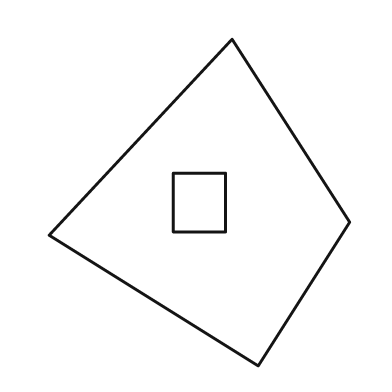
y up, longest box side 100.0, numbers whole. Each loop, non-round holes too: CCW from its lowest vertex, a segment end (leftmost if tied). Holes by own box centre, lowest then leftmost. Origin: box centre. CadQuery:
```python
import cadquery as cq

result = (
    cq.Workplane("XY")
    .moveTo(18.0, -50.0)
    .lineTo(46.0, -6.0)
    .lineTo(10.0, 50.0)
    .lineTo(-46.0, -10.0)
    .close()
    .moveTo(-8.0, -9.0)
    .lineTo(8.0, -9.0)
    .lineTo(8.0, 9.0)
    .lineTo(-8.0, 9.0)
    .close()
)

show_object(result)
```